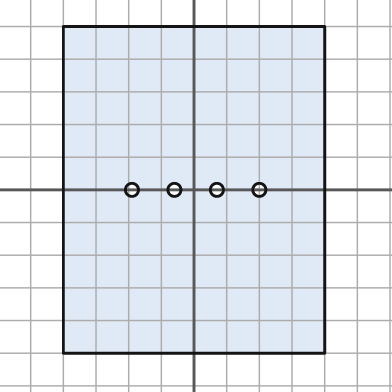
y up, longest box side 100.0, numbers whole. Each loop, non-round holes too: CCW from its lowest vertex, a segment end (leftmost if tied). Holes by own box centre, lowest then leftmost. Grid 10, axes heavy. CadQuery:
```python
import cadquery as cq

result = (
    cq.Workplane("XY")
    .moveTo(-40.0, -50.0)
    .lineTo(40.0, -50.0)
    .lineTo(40.0, 50.0)
    .lineTo(-40.0, 50.0)
    .close()
    .moveTo(-19.0, 0.0)
    .circle(2.0)
    .moveTo(-6.0, 0.0)
    .circle(2.0)
    .moveTo(7.0, 0.0)
    .circle(2.0)
    .moveTo(20.0, 0.0)
    .circle(2.0)
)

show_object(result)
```